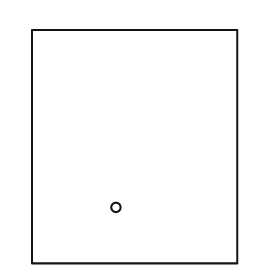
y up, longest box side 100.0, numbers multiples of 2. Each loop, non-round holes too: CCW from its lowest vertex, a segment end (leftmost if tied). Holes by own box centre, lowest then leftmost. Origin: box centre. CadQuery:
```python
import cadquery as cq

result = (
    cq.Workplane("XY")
    .moveTo(-44.0, -50.0)
    .lineTo(44.0, -50.0)
    .lineTo(44.0, 50.0)
    .lineTo(-44.0, 50.0)
    .close()
    .moveTo(-8.0, -26.0)
    .circle(2.0)
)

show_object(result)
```